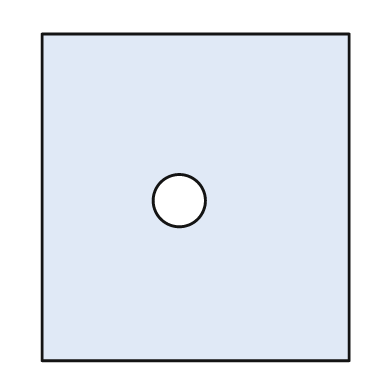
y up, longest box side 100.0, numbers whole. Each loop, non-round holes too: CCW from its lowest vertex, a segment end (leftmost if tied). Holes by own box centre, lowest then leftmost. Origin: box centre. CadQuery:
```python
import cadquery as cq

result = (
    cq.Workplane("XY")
    .moveTo(-47.0, -50.0)
    .lineTo(47.0, -50.0)
    .lineTo(47.0, 50.0)
    .lineTo(-47.0, 50.0)
    .close()
    .moveTo(-5.0, -1.0)
    .circle(8.0)
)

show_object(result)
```